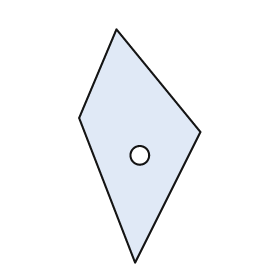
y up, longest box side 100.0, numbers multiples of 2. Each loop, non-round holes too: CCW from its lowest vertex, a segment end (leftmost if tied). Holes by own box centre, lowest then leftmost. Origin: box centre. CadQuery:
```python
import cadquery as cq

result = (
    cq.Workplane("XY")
    .moveTo(-2.0, -50.0)
    .lineTo(26.0, 6.0)
    .lineTo(-10.0, 50.0)
    .lineTo(-26.0, 12.0)
    .close()
    .moveTo(0.0, -4.0)
    .circle(4.0)
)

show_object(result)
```